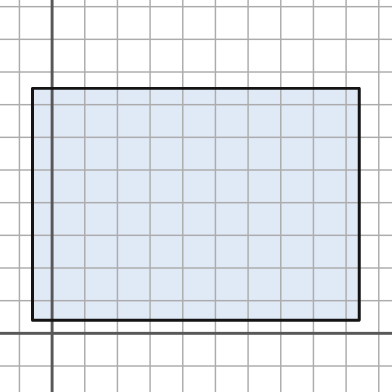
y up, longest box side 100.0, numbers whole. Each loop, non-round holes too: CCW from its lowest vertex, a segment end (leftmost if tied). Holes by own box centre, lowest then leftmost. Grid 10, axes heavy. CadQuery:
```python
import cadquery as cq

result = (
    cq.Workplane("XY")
    .moveTo(-6.0, 4.0)
    .lineTo(94.0, 4.0)
    .lineTo(94.0, 75.0)
    .lineTo(-6.0, 75.0)
    .close()
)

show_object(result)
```